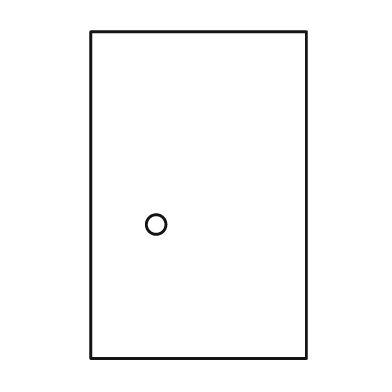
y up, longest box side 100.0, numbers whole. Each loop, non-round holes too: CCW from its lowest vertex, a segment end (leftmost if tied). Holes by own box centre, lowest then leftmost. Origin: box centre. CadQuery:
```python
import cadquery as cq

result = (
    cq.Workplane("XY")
    .moveTo(-33.0, -50.0)
    .lineTo(33.0, -50.0)
    .lineTo(33.0, 50.0)
    .lineTo(-33.0, 50.0)
    .close()
    .moveTo(-13.0, -9.0)
    .circle(3.0)
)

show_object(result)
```